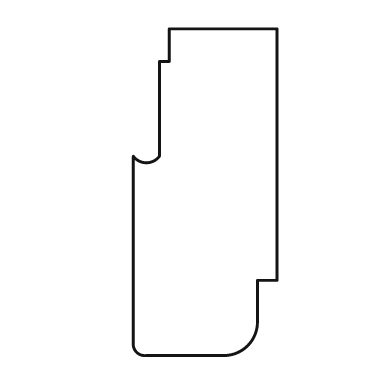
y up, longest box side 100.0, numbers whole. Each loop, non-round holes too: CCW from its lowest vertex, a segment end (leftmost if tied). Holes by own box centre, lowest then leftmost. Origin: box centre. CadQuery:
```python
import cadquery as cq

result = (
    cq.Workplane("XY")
    .moveTo(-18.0, -50.0)
    .lineTo(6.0, -50.0)
    .threePointArc((13.0, -47.0), (16.0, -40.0))
    .lineTo(16.0, -27.0)
    .lineTo(22.0, -27.0)
    .lineTo(22.0, 50.0)
    .lineTo(-11.0, 50.0)
    .lineTo(-11.0, 40.0)
    .lineTo(-14.0, 40.0)
    .lineTo(-14.0, 11.0)
    .threePointArc((-18.0, 9.0), (-22.0, 11.0))
    .lineTo(-22.0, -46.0)
    .threePointArc((-21.0, -49.0), (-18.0, -50.0))
    .close()
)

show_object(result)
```